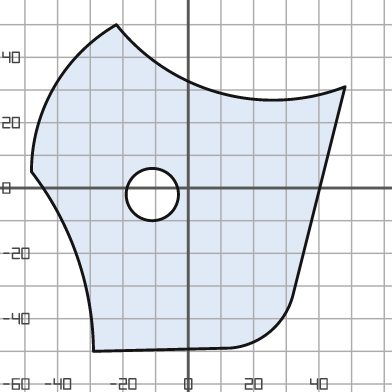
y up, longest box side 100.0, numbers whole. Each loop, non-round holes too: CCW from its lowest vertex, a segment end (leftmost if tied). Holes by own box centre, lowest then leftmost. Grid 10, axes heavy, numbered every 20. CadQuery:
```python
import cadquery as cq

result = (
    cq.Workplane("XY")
    .moveTo(-29.0, -50.0)
    .lineTo(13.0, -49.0)
    .threePointArc((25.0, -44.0), (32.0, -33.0))
    .lineTo(48.0, 31.0)
    .threePointArc((10.0, 29.0), (-22.0, 50.0))
    .threePointArc((-41.0, 31.0), (-48.0, 5.0))
    .threePointArc((-34.0, -21.0), (-29.0, -50.0))
    .close()
    .moveTo(-11.0, -2.0)
    .circle(8.0)
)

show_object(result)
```